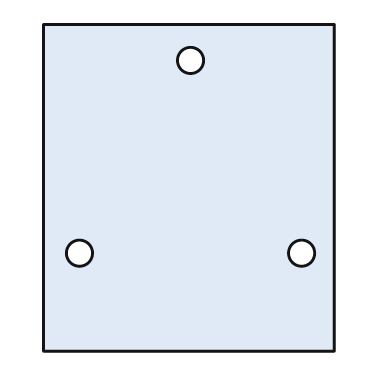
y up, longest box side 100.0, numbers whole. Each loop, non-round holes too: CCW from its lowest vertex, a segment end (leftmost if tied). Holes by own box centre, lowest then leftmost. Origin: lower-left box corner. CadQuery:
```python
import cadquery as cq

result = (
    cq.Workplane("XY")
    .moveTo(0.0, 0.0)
    .lineTo(89.0, 0.0)
    .lineTo(89.0, 100.0)
    .lineTo(0.0, 100.0)
    .close()
    .moveTo(11.0, 30.0)
    .circle(4.0)
    .moveTo(79.0, 30.0)
    .circle(4.0)
    .moveTo(45.0, 89.0)
    .circle(4.0)
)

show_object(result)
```